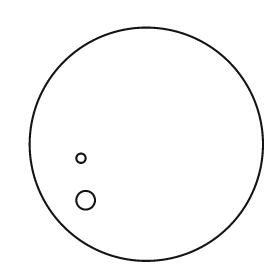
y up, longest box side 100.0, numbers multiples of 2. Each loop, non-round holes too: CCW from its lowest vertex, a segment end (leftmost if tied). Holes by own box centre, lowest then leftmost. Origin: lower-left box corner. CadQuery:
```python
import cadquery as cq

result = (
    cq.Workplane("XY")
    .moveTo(50.0, 50.0)
    .circle(50.0)
    .moveTo(24.0, 26.0)
    .circle(4.0)
    .moveTo(22.0, 44.0)
    .circle(2.0)
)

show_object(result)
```